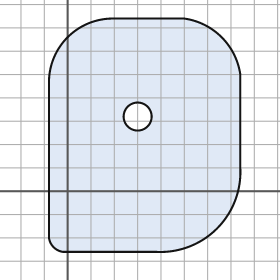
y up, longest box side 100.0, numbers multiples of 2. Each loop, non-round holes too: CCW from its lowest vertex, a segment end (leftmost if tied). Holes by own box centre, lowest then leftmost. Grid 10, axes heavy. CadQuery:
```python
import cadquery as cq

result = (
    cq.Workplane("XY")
    .moveTo(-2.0, -26.0)
    .lineTo(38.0, -26.0)
    .threePointArc((64.0, -16.0), (74.0, 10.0))
    .lineTo(74.0, 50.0)
    .threePointArc((66.0, 66.0), (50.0, 74.0))
    .lineTo(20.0, 74.0)
    .threePointArc((0.0, 66.0), (-8.0, 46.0))
    .lineTo(-8.0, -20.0)
    .threePointArc((-6.0, -24.0), (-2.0, -26.0))
    .close()
    .moveTo(30.0, 32.0)
    .circle(6.0)
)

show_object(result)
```